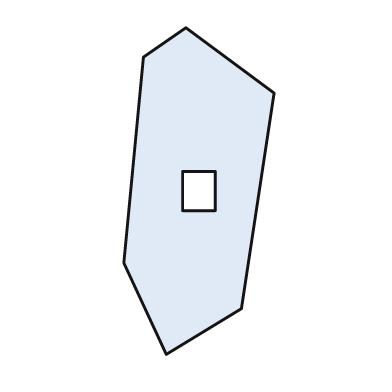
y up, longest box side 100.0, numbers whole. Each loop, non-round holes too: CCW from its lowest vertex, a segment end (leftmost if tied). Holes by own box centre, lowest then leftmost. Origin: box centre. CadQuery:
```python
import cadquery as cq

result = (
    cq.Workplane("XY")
    .moveTo(-10.0, -50.0)
    .lineTo(13.0, -36.0)
    .lineTo(23.0, 30.0)
    .lineTo(-4.0, 50.0)
    .lineTo(-17.0, 41.0)
    .lineTo(-23.0, -22.0)
    .close()
    .moveTo(-5.0, -6.0)
    .lineTo(5.0, -6.0)
    .lineTo(5.0, 6.0)
    .lineTo(-5.0, 6.0)
    .close()
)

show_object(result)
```